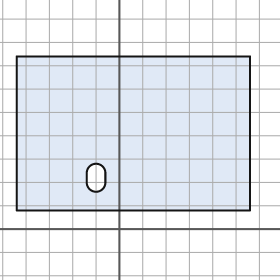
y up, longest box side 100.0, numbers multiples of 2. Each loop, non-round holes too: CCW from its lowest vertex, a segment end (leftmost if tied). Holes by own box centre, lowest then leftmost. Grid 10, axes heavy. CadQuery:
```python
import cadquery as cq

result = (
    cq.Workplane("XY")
    .moveTo(-44.0, 8.0)
    .lineTo(56.0, 8.0)
    .lineTo(56.0, 74.0)
    .lineTo(-44.0, 74.0)
    .close()
    .moveTo(-14.0, 20.0)
    .threePointArc((-10.0, 16.0), (-6.0, 20.0))
    .lineTo(-6.0, 24.0)
    .threePointArc((-10.0, 28.0), (-14.0, 24.0))
    .close()
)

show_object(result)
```